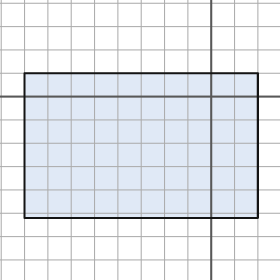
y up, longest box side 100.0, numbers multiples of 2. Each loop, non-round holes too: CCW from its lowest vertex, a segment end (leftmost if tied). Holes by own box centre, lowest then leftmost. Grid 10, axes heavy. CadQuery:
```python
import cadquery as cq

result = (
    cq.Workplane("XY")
    .moveTo(-80.0, -52.0)
    .lineTo(20.0, -52.0)
    .lineTo(20.0, 10.0)
    .lineTo(-80.0, 10.0)
    .close()
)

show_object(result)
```